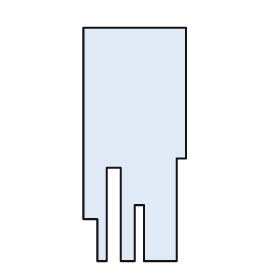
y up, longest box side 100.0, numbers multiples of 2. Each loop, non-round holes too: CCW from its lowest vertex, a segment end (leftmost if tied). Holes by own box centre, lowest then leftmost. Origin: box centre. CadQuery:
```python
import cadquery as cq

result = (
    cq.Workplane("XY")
    .moveTo(-16.0, -50.0)
    .lineTo(-12.0, -50.0)
    .lineTo(-12.0, -10.0)
    .lineTo(-6.0, -10.0)
    .lineTo(-6.0, -50.0)
    .lineTo(0.0, -50.0)
    .lineTo(0.0, -26.0)
    .lineTo(4.0, -26.0)
    .lineTo(4.0, -50.0)
    .lineTo(18.0, -50.0)
    .lineTo(18.0, -6.0)
    .lineTo(22.0, -6.0)
    .lineTo(22.0, 50.0)
    .lineTo(-22.0, 50.0)
    .lineTo(-22.0, -32.0)
    .lineTo(-16.0, -32.0)
    .close()
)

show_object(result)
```